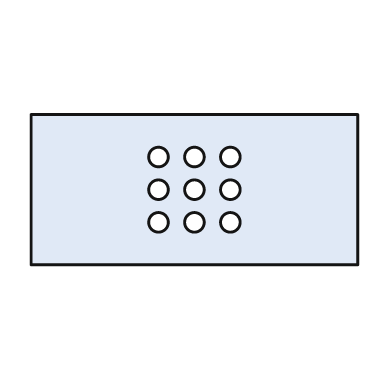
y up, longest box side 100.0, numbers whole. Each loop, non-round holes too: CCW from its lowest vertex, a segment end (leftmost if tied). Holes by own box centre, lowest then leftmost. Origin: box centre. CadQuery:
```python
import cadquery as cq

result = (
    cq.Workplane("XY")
    .moveTo(-50.0, -23.0)
    .lineTo(50.0, -23.0)
    .lineTo(50.0, 23.0)
    .lineTo(-50.0, 23.0)
    .close()
    .moveTo(-11.0, -10.0)
    .circle(3.0)
    .moveTo(0.0, -10.0)
    .circle(3.0)
    .moveTo(11.0, -10.0)
    .circle(3.0)
    .moveTo(-11.0, 0.0)
    .circle(3.0)
    .moveTo(0.0, 0.0)
    .circle(3.0)
    .moveTo(11.0, 0.0)
    .circle(3.0)
    .moveTo(-11.0, 10.0)
    .circle(3.0)
    .moveTo(0.0, 10.0)
    .circle(3.0)
    .moveTo(11.0, 10.0)
    .circle(3.0)
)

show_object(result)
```